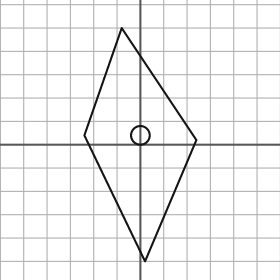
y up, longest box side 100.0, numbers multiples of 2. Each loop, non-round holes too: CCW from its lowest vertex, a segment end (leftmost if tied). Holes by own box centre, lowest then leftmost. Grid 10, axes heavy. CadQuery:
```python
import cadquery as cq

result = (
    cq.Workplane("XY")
    .moveTo(2.0, -50.0)
    .lineTo(24.0, 2.0)
    .lineTo(-8.0, 50.0)
    .lineTo(-24.0, 4.0)
    .close()
    .moveTo(0.0, 4.0)
    .circle(4.0)
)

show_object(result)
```